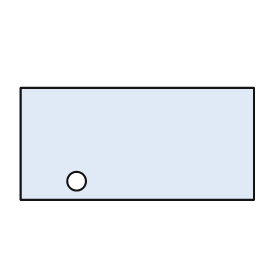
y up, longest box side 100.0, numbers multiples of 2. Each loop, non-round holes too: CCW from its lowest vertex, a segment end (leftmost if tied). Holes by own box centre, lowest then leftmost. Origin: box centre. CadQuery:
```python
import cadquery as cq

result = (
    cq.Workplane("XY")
    .moveTo(-50.0, -24.0)
    .lineTo(50.0, -24.0)
    .lineTo(50.0, 24.0)
    .lineTo(-50.0, 24.0)
    .close()
    .moveTo(-26.0, -16.0)
    .circle(4.0)
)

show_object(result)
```